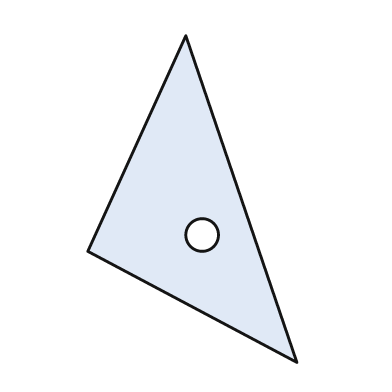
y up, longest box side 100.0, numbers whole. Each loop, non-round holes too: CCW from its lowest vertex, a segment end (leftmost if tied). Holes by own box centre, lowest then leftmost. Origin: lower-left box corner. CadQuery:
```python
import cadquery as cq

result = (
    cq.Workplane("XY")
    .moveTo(64.0, 0.0)
    .lineTo(30.0, 100.0)
    .lineTo(0.0, 34.0)
    .close()
    .moveTo(35.0, 39.0)
    .circle(5.0)
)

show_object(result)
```